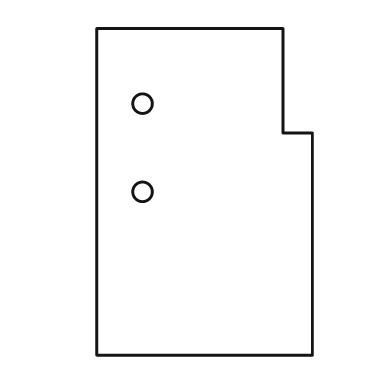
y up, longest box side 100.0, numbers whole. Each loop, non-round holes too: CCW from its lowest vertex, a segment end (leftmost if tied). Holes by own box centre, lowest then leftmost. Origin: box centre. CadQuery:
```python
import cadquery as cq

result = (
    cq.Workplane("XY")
    .moveTo(-33.0, -50.0)
    .lineTo(33.0, -50.0)
    .lineTo(33.0, 18.0)
    .lineTo(24.0, 18.0)
    .lineTo(24.0, 50.0)
    .lineTo(-33.0, 50.0)
    .close()
    .moveTo(-19.0, 0.0)
    .circle(3.0)
    .moveTo(-19.0, 27.0)
    .circle(3.0)
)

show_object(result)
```